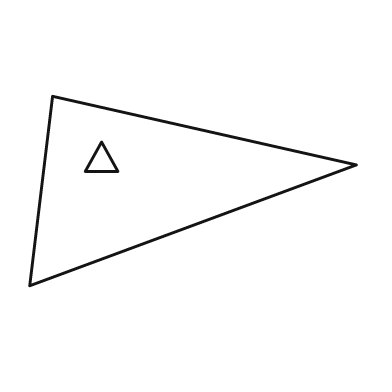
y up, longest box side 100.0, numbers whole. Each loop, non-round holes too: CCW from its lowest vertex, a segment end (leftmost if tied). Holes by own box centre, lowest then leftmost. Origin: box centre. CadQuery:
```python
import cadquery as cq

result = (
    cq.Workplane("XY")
    .moveTo(-50.0, -29.0)
    .lineTo(50.0, 8.0)
    .lineTo(-43.0, 29.0)
    .close()
    .moveTo(-33.0, 6.0)
    .lineTo(-23.0, 6.0)
    .lineTo(-28.0, 15.0)
    .close()
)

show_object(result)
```